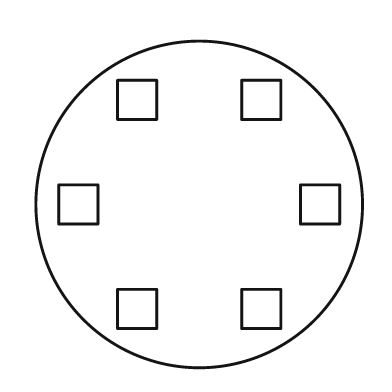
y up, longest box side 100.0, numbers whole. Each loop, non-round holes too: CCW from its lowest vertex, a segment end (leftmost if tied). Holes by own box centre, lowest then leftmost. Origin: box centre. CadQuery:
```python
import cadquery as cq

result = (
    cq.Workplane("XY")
    .moveTo(0.0, 0.0)
    .circle(50.0)
    .moveTo(-25.0, -38.0)
    .lineTo(-13.0, -38.0)
    .lineTo(-13.0, -26.0)
    .lineTo(-25.0, -26.0)
    .close()
    .moveTo(13.0, -38.0)
    .lineTo(25.0, -38.0)
    .lineTo(25.0, -26.0)
    .lineTo(13.0, -26.0)
    .close()
    .moveTo(-43.0, -6.0)
    .lineTo(-31.0, -6.0)
    .lineTo(-31.0, 6.0)
    .lineTo(-43.0, 6.0)
    .close()
    .moveTo(31.0, -6.0)
    .lineTo(43.0, -6.0)
    .lineTo(43.0, 6.0)
    .lineTo(31.0, 6.0)
    .close()
    .moveTo(-25.0, 26.0)
    .lineTo(-13.0, 26.0)
    .lineTo(-13.0, 38.0)
    .lineTo(-25.0, 38.0)
    .close()
    .moveTo(13.0, 26.0)
    .lineTo(25.0, 26.0)
    .lineTo(25.0, 38.0)
    .lineTo(13.0, 38.0)
    .close()
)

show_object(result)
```